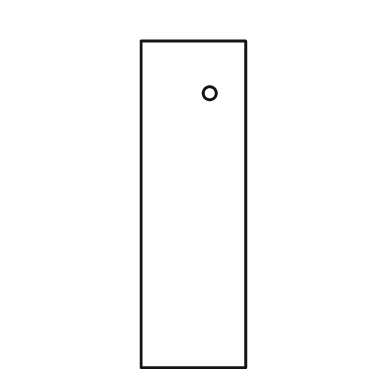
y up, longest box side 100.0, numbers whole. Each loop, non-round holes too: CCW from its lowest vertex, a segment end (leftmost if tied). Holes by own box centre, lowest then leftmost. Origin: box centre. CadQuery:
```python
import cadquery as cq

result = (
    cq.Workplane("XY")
    .moveTo(-16.0, -50.0)
    .lineTo(16.0, -50.0)
    .lineTo(16.0, 50.0)
    .lineTo(-16.0, 50.0)
    .close()
    .moveTo(5.0, 34.0)
    .circle(2.0)
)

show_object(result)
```